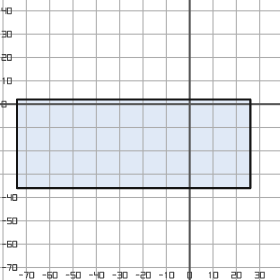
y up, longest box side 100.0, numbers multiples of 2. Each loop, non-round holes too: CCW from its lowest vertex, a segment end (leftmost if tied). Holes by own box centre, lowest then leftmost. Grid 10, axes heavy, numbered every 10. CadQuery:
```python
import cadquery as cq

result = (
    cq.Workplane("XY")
    .moveTo(-74.0, -36.0)
    .lineTo(26.0, -36.0)
    .lineTo(26.0, 2.0)
    .lineTo(-74.0, 2.0)
    .close()
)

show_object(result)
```